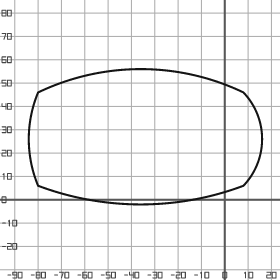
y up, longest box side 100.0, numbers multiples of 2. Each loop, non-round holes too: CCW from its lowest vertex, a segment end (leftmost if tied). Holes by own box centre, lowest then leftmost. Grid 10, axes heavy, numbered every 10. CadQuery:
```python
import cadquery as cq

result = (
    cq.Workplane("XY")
    .moveTo(-80.0, 6.0)
    .threePointArc((-36.0, -2.0), (8.0, 6.0))
    .threePointArc((16.0, 26.0), (8.0, 46.0))
    .threePointArc((-36.0, 56.0), (-80.0, 46.0))
    .threePointArc((-84.0, 26.0), (-80.0, 6.0))
    .close()
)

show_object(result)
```